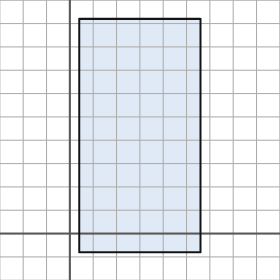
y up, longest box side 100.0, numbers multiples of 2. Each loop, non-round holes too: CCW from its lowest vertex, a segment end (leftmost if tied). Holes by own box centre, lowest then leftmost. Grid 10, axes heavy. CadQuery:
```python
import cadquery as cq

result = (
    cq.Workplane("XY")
    .moveTo(4.0, -8.0)
    .lineTo(56.0, -8.0)
    .lineTo(56.0, 92.0)
    .lineTo(4.0, 92.0)
    .close()
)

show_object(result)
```